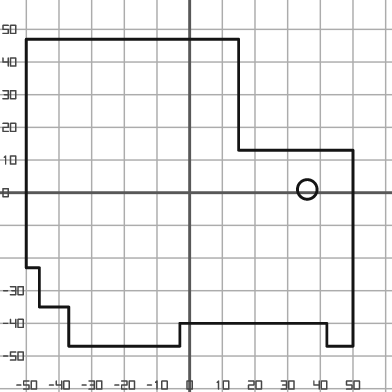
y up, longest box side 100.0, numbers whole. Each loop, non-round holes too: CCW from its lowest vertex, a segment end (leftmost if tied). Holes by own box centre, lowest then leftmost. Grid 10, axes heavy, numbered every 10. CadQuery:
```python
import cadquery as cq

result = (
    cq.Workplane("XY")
    .moveTo(-37.0, -47.0)
    .lineTo(-3.0, -47.0)
    .lineTo(-3.0, -40.0)
    .lineTo(42.0, -40.0)
    .lineTo(42.0, -47.0)
    .lineTo(50.0, -47.0)
    .lineTo(50.0, 13.0)
    .lineTo(15.0, 13.0)
    .lineTo(15.0, 47.0)
    .lineTo(-50.0, 47.0)
    .lineTo(-50.0, -23.0)
    .lineTo(-46.0, -23.0)
    .lineTo(-46.0, -35.0)
    .lineTo(-37.0, -35.0)
    .close()
    .moveTo(36.0, 1.0)
    .circle(3.0)
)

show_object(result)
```